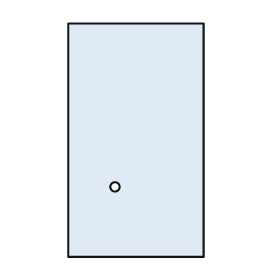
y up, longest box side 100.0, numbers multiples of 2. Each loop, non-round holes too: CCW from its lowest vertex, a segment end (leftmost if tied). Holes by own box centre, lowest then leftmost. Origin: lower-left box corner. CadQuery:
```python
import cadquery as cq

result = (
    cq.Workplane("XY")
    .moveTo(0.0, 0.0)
    .lineTo(58.0, 0.0)
    .lineTo(58.0, 100.0)
    .lineTo(0.0, 100.0)
    .close()
    .moveTo(20.0, 30.0)
    .circle(2.0)
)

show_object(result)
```